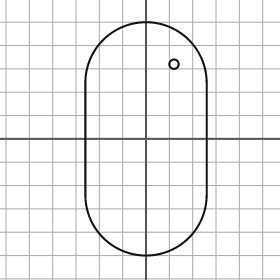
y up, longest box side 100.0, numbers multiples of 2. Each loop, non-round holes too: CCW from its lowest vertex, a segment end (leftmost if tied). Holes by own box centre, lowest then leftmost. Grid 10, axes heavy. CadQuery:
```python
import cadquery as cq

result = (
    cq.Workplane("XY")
    .moveTo(-26.0, -24.0)
    .threePointArc((0.0, -50.0), (26.0, -24.0))
    .lineTo(26.0, 24.0)
    .threePointArc((0.0, 50.0), (-26.0, 24.0))
    .close()
    .moveTo(12.0, 32.0)
    .circle(2.0)
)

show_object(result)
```